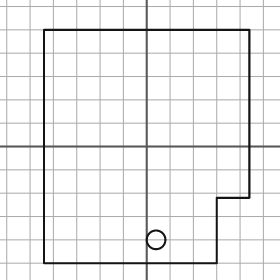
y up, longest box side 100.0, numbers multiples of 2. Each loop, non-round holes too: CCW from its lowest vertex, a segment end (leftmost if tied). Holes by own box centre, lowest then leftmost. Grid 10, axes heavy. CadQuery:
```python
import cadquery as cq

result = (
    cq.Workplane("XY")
    .moveTo(-44.0, -50.0)
    .lineTo(30.0, -50.0)
    .lineTo(30.0, -22.0)
    .lineTo(44.0, -22.0)
    .lineTo(44.0, 50.0)
    .lineTo(-44.0, 50.0)
    .close()
    .moveTo(4.0, -40.0)
    .circle(4.0)
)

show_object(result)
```